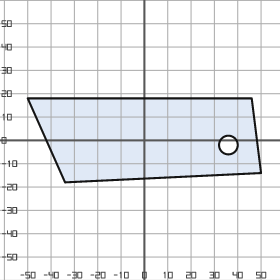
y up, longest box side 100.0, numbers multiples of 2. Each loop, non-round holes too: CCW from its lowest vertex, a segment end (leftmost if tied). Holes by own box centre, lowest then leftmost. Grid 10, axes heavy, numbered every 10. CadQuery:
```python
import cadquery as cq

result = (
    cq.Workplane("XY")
    .moveTo(-34.0, -18.0)
    .lineTo(50.0, -14.0)
    .lineTo(46.0, 18.0)
    .lineTo(-50.0, 18.0)
    .close()
    .moveTo(36.0, -2.0)
    .circle(4.0)
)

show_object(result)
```